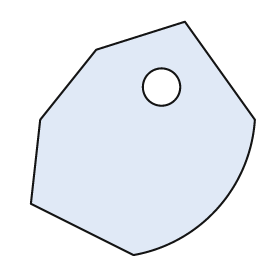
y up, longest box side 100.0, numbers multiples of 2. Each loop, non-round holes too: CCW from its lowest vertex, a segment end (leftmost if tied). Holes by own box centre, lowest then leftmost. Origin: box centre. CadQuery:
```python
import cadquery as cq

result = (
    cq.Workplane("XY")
    .moveTo(-4.0, -50.0)
    .threePointArc((32.0, -30.0), (48.0, 8.0))
    .lineTo(18.0, 50.0)
    .lineTo(-20.0, 38.0)
    .lineTo(-44.0, 8.0)
    .lineTo(-48.0, -28.0)
    .close()
    .moveTo(8.0, 22.0)
    .circle(8.0)
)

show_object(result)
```